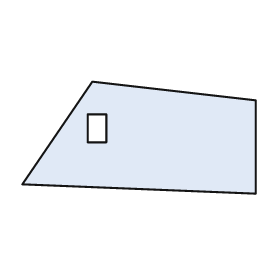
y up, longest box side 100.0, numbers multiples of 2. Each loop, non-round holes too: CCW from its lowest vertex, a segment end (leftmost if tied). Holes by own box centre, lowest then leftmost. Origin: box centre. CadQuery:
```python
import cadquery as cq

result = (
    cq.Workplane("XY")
    .moveTo(50.0, -24.0)
    .lineTo(50.0, 16.0)
    .lineTo(-20.0, 24.0)
    .lineTo(-50.0, -20.0)
    .close()
    .moveTo(-22.0, -2.0)
    .lineTo(-14.0, -2.0)
    .lineTo(-14.0, 10.0)
    .lineTo(-22.0, 10.0)
    .close()
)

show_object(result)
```